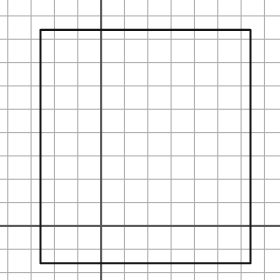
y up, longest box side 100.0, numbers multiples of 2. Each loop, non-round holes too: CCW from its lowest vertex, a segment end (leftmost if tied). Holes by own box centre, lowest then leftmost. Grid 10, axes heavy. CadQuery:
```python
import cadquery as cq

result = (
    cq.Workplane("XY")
    .moveTo(-26.0, -16.0)
    .lineTo(64.0, -16.0)
    .lineTo(64.0, 84.0)
    .lineTo(-26.0, 84.0)
    .close()
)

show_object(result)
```